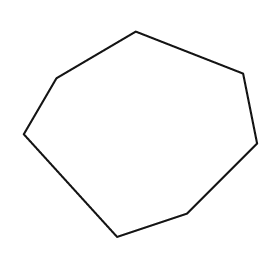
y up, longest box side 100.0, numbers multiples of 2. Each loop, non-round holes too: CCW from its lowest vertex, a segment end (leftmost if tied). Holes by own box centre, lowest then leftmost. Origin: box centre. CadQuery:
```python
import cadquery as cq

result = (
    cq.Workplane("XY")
    .moveTo(-10.0, -44.0)
    .lineTo(20.0, -34.0)
    .lineTo(50.0, -4.0)
    .lineTo(44.0, 26.0)
    .lineTo(-2.0, 44.0)
    .lineTo(-36.0, 24.0)
    .lineTo(-50.0, 0.0)
    .close()
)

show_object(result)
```